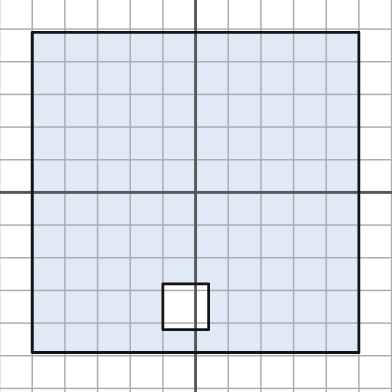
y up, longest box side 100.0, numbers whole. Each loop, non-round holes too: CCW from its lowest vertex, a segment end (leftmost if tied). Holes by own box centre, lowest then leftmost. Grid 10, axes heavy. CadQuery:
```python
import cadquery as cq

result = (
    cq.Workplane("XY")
    .moveTo(-50.0, -49.0)
    .lineTo(50.0, -49.0)
    .lineTo(50.0, 49.0)
    .lineTo(-50.0, 49.0)
    .close()
    .moveTo(-10.0, -42.0)
    .lineTo(4.0, -42.0)
    .lineTo(4.0, -28.0)
    .lineTo(-10.0, -28.0)
    .close()
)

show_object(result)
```